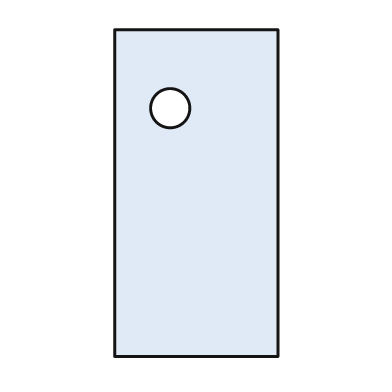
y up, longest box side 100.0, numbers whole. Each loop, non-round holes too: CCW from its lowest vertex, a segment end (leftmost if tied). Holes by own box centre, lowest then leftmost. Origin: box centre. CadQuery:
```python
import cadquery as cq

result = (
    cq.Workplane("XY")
    .moveTo(-25.0, -50.0)
    .lineTo(25.0, -50.0)
    .lineTo(25.0, 50.0)
    .lineTo(-25.0, 50.0)
    .close()
    .moveTo(-8.0, 26.0)
    .circle(6.0)
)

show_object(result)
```